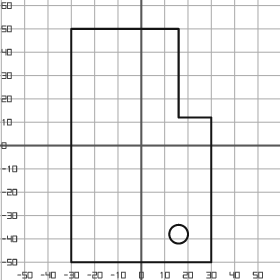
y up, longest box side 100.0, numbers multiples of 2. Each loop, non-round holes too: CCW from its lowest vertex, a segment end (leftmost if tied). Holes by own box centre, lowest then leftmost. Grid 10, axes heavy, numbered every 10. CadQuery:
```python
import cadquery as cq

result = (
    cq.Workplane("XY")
    .moveTo(-30.0, -50.0)
    .lineTo(30.0, -50.0)
    .lineTo(30.0, 12.0)
    .lineTo(16.0, 12.0)
    .lineTo(16.0, 50.0)
    .lineTo(-30.0, 50.0)
    .close()
    .moveTo(16.0, -38.0)
    .circle(4.0)
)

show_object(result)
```